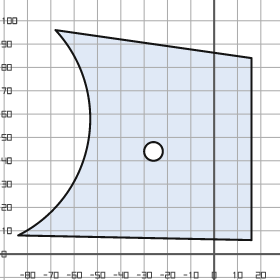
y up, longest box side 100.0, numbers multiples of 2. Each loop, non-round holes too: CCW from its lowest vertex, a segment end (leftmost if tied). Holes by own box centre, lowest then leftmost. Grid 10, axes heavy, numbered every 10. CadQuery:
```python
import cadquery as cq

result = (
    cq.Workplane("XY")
    .moveTo(16.0, 6.0)
    .lineTo(16.0, 84.0)
    .lineTo(-68.0, 96.0)
    .threePointArc((-54.0, 48.0), (-84.0, 8.0))
    .close()
    .moveTo(-26.0, 44.0)
    .circle(4.0)
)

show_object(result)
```